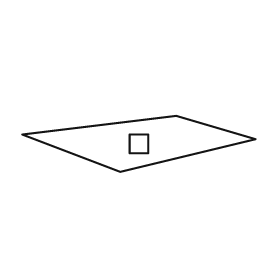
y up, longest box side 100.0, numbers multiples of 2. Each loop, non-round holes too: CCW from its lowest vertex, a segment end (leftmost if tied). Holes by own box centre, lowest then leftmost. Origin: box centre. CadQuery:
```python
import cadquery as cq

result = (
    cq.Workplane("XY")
    .moveTo(-8.0, -12.0)
    .lineTo(50.0, 2.0)
    .lineTo(16.0, 12.0)
    .lineTo(-50.0, 4.0)
    .close()
    .moveTo(-4.0, -4.0)
    .lineTo(4.0, -4.0)
    .lineTo(4.0, 4.0)
    .lineTo(-4.0, 4.0)
    .close()
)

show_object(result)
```